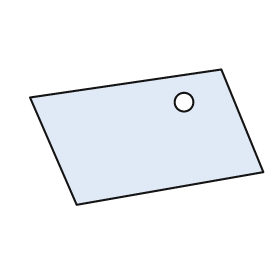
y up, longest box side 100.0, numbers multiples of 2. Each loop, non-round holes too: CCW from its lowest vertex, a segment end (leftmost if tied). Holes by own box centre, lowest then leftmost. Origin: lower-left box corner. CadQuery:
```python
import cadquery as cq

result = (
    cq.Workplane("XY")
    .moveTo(20.0, 0.0)
    .lineTo(100.0, 14.0)
    .lineTo(82.0, 58.0)
    .lineTo(0.0, 46.0)
    .close()
    .moveTo(66.0, 44.0)
    .circle(4.0)
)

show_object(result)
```